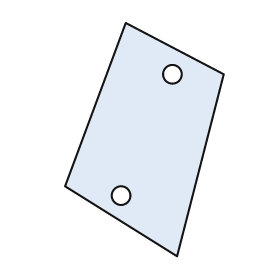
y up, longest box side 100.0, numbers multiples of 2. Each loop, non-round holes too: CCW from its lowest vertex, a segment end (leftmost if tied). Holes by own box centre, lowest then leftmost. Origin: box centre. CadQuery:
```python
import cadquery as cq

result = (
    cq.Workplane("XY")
    .moveTo(14.0, -50.0)
    .lineTo(34.0, 28.0)
    .lineTo(-8.0, 50.0)
    .lineTo(-34.0, -20.0)
    .close()
    .moveTo(-10.0, -24.0)
    .circle(4.0)
    .moveTo(12.0, 28.0)
    .circle(4.0)
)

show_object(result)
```